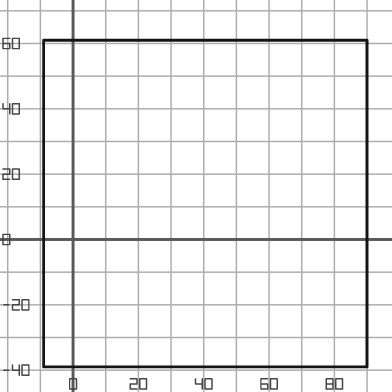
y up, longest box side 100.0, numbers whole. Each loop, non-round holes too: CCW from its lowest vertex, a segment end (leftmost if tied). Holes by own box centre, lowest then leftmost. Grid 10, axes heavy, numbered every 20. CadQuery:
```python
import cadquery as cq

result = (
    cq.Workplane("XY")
    .moveTo(-9.0, -39.0)
    .lineTo(90.0, -39.0)
    .lineTo(90.0, 61.0)
    .lineTo(-9.0, 61.0)
    .close()
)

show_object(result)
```